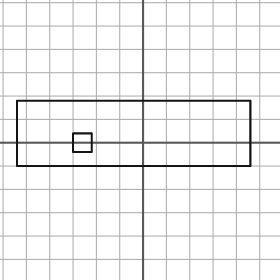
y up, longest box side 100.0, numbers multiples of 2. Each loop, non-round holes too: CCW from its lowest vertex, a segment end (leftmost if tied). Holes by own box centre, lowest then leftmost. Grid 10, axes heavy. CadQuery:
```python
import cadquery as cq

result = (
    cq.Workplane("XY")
    .moveTo(-54.0, -10.0)
    .lineTo(46.0, -10.0)
    .lineTo(46.0, 18.0)
    .lineTo(-54.0, 18.0)
    .close()
    .moveTo(-30.0, -4.0)
    .lineTo(-22.0, -4.0)
    .lineTo(-22.0, 4.0)
    .lineTo(-30.0, 4.0)
    .close()
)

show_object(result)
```